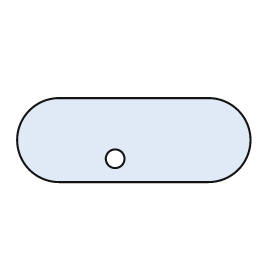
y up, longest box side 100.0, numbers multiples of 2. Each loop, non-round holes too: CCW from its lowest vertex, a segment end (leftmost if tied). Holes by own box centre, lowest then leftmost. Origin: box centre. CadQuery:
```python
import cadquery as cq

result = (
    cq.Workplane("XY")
    .moveTo(-32.0, -18.0)
    .lineTo(32.0, -18.0)
    .threePointArc((50.0, 0.0), (32.0, 18.0))
    .lineTo(-32.0, 18.0)
    .threePointArc((-50.0, 0.0), (-32.0, -18.0))
    .close()
    .moveTo(-8.0, -8.0)
    .circle(4.0)
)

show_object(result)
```